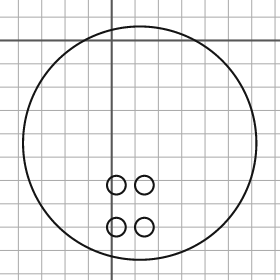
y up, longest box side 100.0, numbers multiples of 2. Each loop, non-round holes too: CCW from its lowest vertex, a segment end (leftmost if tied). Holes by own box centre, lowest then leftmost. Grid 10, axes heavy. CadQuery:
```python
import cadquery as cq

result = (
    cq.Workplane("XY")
    .moveTo(12.0, -44.0)
    .circle(50.0)
    .moveTo(2.0, -80.0)
    .circle(4.0)
    .moveTo(14.0, -80.0)
    .circle(4.0)
    .moveTo(2.0, -62.0)
    .circle(4.0)
    .moveTo(14.0, -62.0)
    .circle(4.0)
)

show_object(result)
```